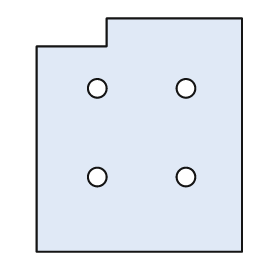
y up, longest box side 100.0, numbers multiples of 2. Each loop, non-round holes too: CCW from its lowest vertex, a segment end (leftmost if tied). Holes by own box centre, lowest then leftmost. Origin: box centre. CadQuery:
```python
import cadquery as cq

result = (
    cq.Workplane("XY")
    .moveTo(-44.0, -50.0)
    .lineTo(44.0, -50.0)
    .lineTo(44.0, 50.0)
    .lineTo(-14.0, 50.0)
    .lineTo(-14.0, 38.0)
    .lineTo(-44.0, 38.0)
    .close()
    .moveTo(-18.0, -18.0)
    .circle(4.0)
    .moveTo(20.0, -18.0)
    .circle(4.0)
    .moveTo(-18.0, 20.0)
    .circle(4.0)
    .moveTo(20.0, 20.0)
    .circle(4.0)
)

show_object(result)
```